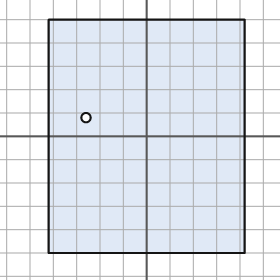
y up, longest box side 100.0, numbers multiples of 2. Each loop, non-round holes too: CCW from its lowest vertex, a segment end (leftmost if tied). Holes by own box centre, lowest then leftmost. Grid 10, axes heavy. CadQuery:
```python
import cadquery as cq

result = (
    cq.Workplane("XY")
    .moveTo(-42.0, -50.0)
    .lineTo(42.0, -50.0)
    .lineTo(42.0, 50.0)
    .lineTo(-42.0, 50.0)
    .close()
    .moveTo(-26.0, 8.0)
    .circle(2.0)
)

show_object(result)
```